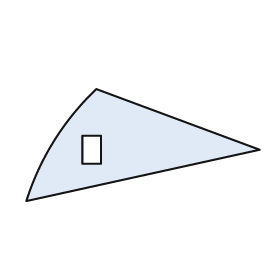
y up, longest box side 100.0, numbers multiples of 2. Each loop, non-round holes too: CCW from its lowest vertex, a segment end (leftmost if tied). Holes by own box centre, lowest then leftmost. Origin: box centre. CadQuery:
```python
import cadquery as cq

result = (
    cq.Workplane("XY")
    .moveTo(-50.0, -24.0)
    .lineTo(50.0, -2.0)
    .lineTo(-20.0, 24.0)
    .threePointArc((-38.0, 2.0), (-50.0, -24.0))
    .close()
    .moveTo(-26.0, -8.0)
    .lineTo(-18.0, -8.0)
    .lineTo(-18.0, 4.0)
    .lineTo(-26.0, 4.0)
    .close()
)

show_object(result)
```